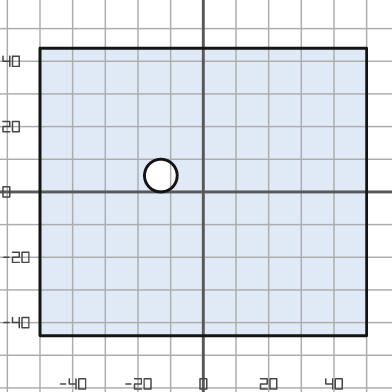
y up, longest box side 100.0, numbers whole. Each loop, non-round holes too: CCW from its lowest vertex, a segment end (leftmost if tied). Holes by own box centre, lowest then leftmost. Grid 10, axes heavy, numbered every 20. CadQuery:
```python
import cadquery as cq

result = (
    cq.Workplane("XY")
    .moveTo(-50.0, -44.0)
    .lineTo(50.0, -44.0)
    .lineTo(50.0, 44.0)
    .lineTo(-50.0, 44.0)
    .close()
    .moveTo(-13.0, 5.0)
    .circle(5.0)
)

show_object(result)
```